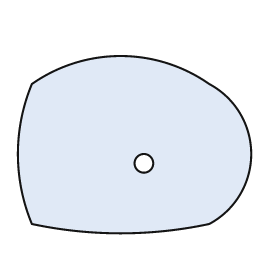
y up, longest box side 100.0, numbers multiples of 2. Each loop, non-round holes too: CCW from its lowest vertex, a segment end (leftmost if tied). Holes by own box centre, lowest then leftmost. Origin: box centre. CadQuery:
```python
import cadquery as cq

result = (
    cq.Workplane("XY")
    .moveTo(-44.0, -34.0)
    .threePointArc((-6.0, -38.0), (32.0, -34.0))
    .threePointArc((50.0, -4.0), (32.0, 26.0))
    .threePointArc((-6.0, 38.0), (-44.0, 26.0))
    .threePointArc((-50.0, -4.0), (-44.0, -34.0))
    .close()
    .moveTo(4.0, -8.0)
    .circle(4.0)
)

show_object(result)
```